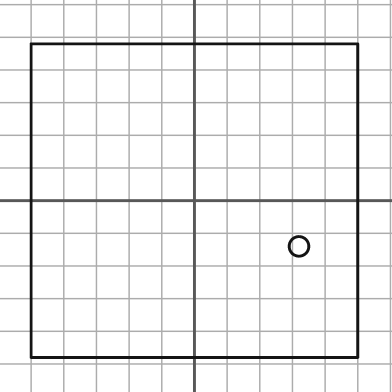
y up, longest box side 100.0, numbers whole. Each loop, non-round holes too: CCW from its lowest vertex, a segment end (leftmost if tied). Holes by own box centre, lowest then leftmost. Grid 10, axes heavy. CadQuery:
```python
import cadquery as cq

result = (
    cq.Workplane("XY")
    .moveTo(-50.0, -48.0)
    .lineTo(50.0, -48.0)
    .lineTo(50.0, 48.0)
    .lineTo(-50.0, 48.0)
    .close()
    .moveTo(32.0, -14.0)
    .circle(3.0)
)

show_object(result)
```